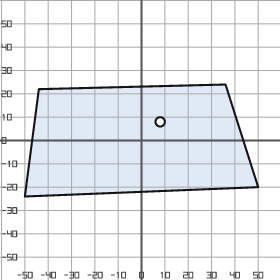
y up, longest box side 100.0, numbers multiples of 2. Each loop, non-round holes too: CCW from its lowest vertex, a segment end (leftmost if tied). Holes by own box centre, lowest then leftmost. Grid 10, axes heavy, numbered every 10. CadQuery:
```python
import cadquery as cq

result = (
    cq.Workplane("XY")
    .moveTo(-50.0, -24.0)
    .lineTo(50.0, -20.0)
    .lineTo(36.0, 24.0)
    .lineTo(-44.0, 22.0)
    .close()
    .moveTo(8.0, 8.0)
    .circle(2.0)
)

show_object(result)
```